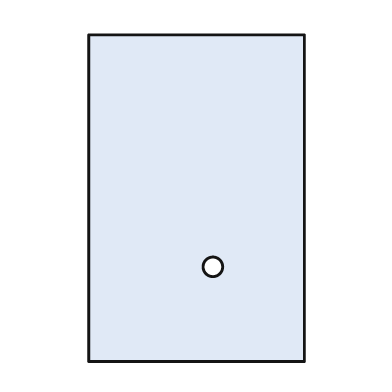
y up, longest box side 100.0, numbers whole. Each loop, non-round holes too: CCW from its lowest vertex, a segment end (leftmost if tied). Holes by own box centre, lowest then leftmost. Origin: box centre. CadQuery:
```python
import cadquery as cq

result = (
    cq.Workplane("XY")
    .moveTo(-33.0, -50.0)
    .lineTo(33.0, -50.0)
    .lineTo(33.0, 50.0)
    .lineTo(-33.0, 50.0)
    .close()
    .moveTo(5.0, -21.0)
    .circle(3.0)
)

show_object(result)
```